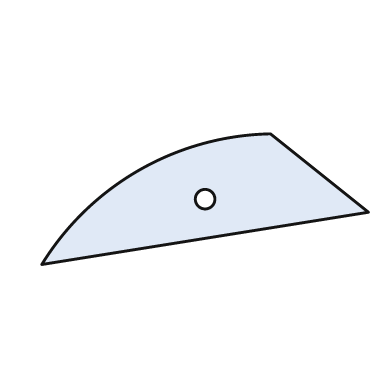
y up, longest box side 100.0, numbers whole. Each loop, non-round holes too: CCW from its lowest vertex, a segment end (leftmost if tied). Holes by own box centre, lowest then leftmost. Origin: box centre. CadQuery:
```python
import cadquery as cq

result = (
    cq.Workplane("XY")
    .moveTo(-50.0, -20.0)
    .lineTo(50.0, -4.0)
    .lineTo(20.0, 20.0)
    .threePointArc((-20.0, 9.0), (-50.0, -20.0))
    .close()
    .moveTo(0.0, 0.0)
    .circle(3.0)
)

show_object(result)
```